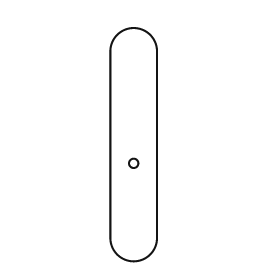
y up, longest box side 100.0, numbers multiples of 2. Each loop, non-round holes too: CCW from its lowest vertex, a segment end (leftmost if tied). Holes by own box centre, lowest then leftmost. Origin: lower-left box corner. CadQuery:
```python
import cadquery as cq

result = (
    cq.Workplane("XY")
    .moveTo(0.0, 10.0)
    .threePointArc((10.0, 0.0), (20.0, 10.0))
    .lineTo(20.0, 90.0)
    .threePointArc((10.0, 100.0), (0.0, 90.0))
    .close()
    .moveTo(10.0, 42.0)
    .circle(2.0)
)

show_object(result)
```